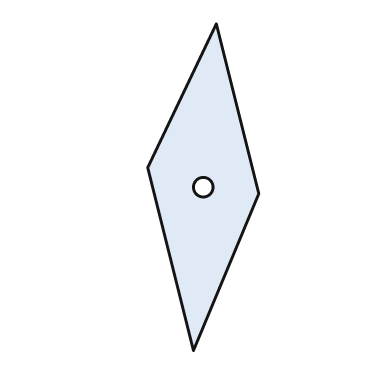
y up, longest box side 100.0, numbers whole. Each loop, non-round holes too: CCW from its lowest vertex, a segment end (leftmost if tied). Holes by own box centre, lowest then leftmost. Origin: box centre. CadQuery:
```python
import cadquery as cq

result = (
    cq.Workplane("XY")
    .moveTo(-3.0, -50.0)
    .lineTo(17.0, -2.0)
    .lineTo(4.0, 50.0)
    .lineTo(-17.0, 6.0)
    .close()
    .moveTo(0.0, 0.0)
    .circle(3.0)
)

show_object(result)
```